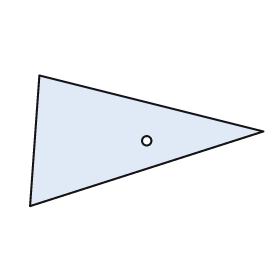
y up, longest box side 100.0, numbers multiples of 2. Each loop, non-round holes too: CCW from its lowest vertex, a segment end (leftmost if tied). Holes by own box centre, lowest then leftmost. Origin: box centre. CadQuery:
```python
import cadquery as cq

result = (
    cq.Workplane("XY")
    .moveTo(-50.0, -28.0)
    .lineTo(50.0, 4.0)
    .lineTo(-46.0, 28.0)
    .close()
    .moveTo(0.0, 0.0)
    .circle(2.0)
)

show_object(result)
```